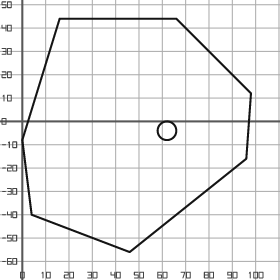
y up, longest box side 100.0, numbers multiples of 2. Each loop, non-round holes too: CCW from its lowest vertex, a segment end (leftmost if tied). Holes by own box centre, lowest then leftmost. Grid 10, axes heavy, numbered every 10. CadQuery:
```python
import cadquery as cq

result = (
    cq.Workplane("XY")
    .moveTo(46.0, -56.0)
    .lineTo(96.0, -16.0)
    .lineTo(98.0, 12.0)
    .lineTo(66.0, 44.0)
    .lineTo(16.0, 44.0)
    .lineTo(0.0, -8.0)
    .lineTo(4.0, -40.0)
    .close()
    .moveTo(62.0, -4.0)
    .circle(4.0)
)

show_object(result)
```